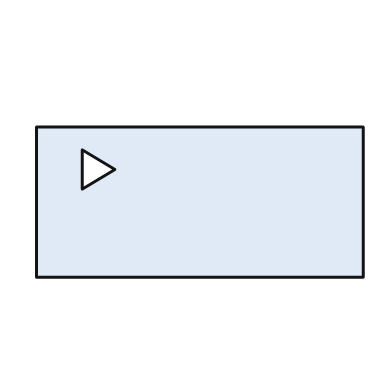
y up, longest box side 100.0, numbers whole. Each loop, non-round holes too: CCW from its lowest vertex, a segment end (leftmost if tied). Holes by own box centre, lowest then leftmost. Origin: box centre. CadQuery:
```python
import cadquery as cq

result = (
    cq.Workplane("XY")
    .moveTo(-50.0, -23.0)
    .lineTo(50.0, -23.0)
    .lineTo(50.0, 23.0)
    .lineTo(-50.0, 23.0)
    .close()
    .moveTo(-36.0, 4.0)
    .lineTo(-26.0, 10.0)
    .lineTo(-36.0, 16.0)
    .close()
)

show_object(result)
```